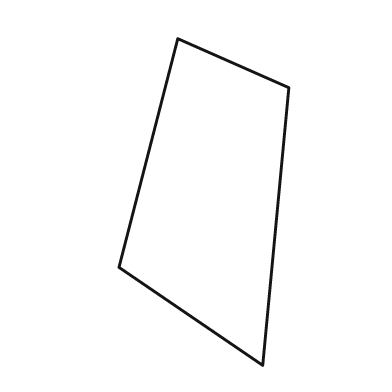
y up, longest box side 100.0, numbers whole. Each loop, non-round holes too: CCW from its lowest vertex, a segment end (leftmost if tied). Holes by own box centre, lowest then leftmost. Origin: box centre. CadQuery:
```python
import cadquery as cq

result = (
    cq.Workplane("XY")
    .moveTo(18.0, -50.0)
    .lineTo(26.0, 35.0)
    .lineTo(-8.0, 50.0)
    .lineTo(-26.0, -20.0)
    .close()
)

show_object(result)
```